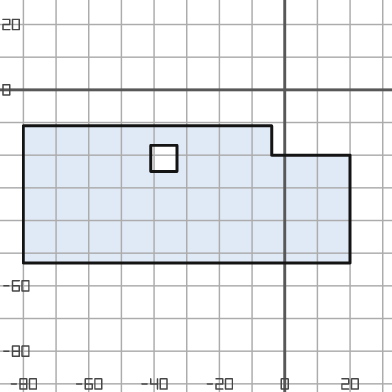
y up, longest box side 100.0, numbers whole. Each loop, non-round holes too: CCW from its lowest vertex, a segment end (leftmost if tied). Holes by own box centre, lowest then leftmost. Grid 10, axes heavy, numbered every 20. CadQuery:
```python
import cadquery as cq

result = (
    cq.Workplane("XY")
    .moveTo(-80.0, -53.0)
    .lineTo(20.0, -53.0)
    .lineTo(20.0, -20.0)
    .lineTo(-4.0, -20.0)
    .lineTo(-4.0, -11.0)
    .lineTo(-80.0, -11.0)
    .close()
    .moveTo(-41.0, -25.0)
    .lineTo(-33.0, -25.0)
    .lineTo(-33.0, -17.0)
    .lineTo(-41.0, -17.0)
    .close()
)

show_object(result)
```